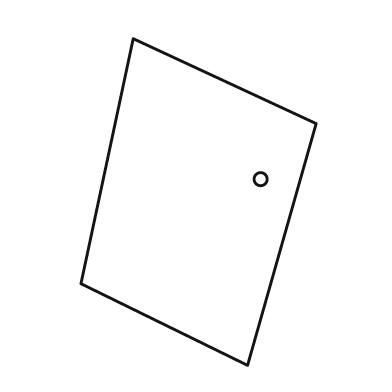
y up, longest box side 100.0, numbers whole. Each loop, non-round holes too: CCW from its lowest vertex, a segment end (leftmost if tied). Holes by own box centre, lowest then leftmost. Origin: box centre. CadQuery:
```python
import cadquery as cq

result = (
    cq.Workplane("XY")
    .moveTo(15.0, -50.0)
    .lineTo(36.0, 24.0)
    .lineTo(-20.0, 50.0)
    .lineTo(-36.0, -25.0)
    .close()
    .moveTo(19.0, 7.0)
    .circle(2.0)
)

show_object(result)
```